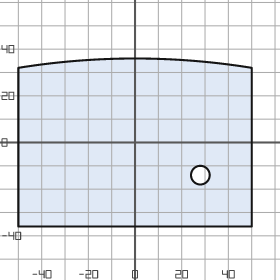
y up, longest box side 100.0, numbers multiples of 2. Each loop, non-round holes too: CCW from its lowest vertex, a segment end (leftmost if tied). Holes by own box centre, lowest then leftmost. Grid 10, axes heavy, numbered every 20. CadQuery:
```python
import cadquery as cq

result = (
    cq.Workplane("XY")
    .moveTo(-50.0, -36.0)
    .lineTo(50.0, -36.0)
    .lineTo(50.0, 32.0)
    .threePointArc((0.0, 36.0), (-50.0, 32.0))
    .close()
    .moveTo(28.0, -14.0)
    .circle(4.0)
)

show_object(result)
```